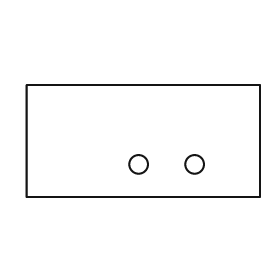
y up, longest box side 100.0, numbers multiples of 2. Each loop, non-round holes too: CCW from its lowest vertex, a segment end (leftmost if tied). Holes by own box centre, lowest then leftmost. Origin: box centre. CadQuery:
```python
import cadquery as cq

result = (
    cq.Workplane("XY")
    .moveTo(-50.0, -24.0)
    .lineTo(50.0, -24.0)
    .lineTo(50.0, 24.0)
    .lineTo(-50.0, 24.0)
    .close()
    .moveTo(-2.0, -10.0)
    .circle(4.0)
    .moveTo(22.0, -10.0)
    .circle(4.0)
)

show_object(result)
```